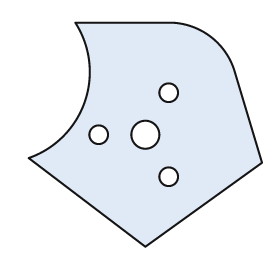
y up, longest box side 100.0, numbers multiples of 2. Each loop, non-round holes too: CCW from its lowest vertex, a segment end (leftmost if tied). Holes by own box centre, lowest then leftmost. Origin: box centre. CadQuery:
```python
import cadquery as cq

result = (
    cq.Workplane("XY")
    .moveTo(0.0, -48.0)
    .lineTo(50.0, -12.0)
    .lineTo(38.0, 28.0)
    .threePointArc((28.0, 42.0), (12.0, 48.0))
    .lineTo(-30.0, 48.0)
    .threePointArc((-26.0, 14.0), (-50.0, -10.0))
    .close()
    .moveTo(10.0, -18.0)
    .circle(4.0)
    .moveTo(-20.0, 0.0)
    .circle(4.0)
    .moveTo(0.0, 0.0)
    .circle(6.0)
    .moveTo(10.0, 18.0)
    .circle(4.0)
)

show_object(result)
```